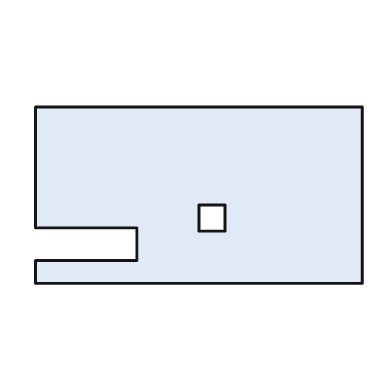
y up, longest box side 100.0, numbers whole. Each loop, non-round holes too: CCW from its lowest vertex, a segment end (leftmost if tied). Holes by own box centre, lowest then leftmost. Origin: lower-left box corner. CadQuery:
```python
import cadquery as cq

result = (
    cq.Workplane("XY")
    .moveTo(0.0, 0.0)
    .lineTo(100.0, 0.0)
    .lineTo(100.0, 54.0)
    .lineTo(0.0, 54.0)
    .lineTo(0.0, 17.0)
    .lineTo(31.0, 17.0)
    .lineTo(31.0, 7.0)
    .lineTo(0.0, 7.0)
    .close()
    .moveTo(50.0, 16.0)
    .lineTo(58.0, 16.0)
    .lineTo(58.0, 24.0)
    .lineTo(50.0, 24.0)
    .close()
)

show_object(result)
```